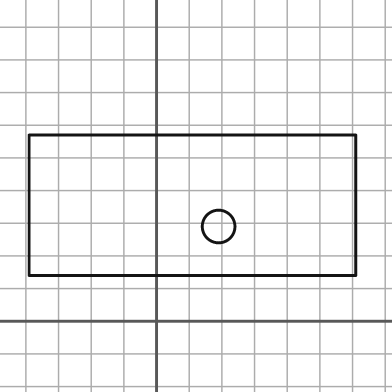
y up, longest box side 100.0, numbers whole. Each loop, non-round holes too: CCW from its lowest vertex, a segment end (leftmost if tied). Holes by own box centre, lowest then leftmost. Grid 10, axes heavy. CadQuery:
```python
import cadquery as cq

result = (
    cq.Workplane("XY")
    .moveTo(-39.0, 14.0)
    .lineTo(61.0, 14.0)
    .lineTo(61.0, 57.0)
    .lineTo(-39.0, 57.0)
    .close()
    .moveTo(19.0, 29.0)
    .circle(5.0)
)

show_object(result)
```